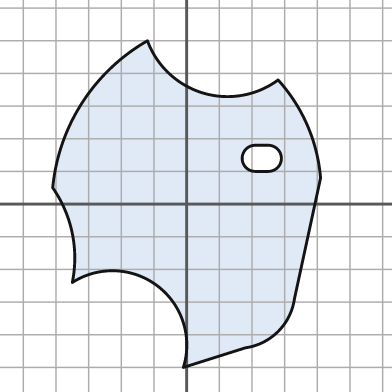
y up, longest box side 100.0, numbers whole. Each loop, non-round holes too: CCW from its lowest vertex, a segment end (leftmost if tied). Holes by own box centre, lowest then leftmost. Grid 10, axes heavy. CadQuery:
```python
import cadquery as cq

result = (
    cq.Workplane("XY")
    .moveTo(-1.0, -50.0)
    .lineTo(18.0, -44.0)
    .threePointArc((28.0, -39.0), (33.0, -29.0))
    .lineTo(41.0, 8.0)
    .threePointArc((37.0, 24.0), (28.0, 38.0))
    .threePointArc((5.0, 34.0), (-12.0, 50.0))
    .threePointArc((-32.0, 31.0), (-41.0, 5.0))
    .threePointArc((-35.0, -9.0), (-35.0, -24.0))
    .threePointArc((-9.0, -25.0), (-1.0, -50.0))
    .close()
    .moveTo(21.0, 10.0)
    .lineTo(25.0, 10.0)
    .threePointArc((29.0, 14.0), (25.0, 18.0))
    .lineTo(21.0, 18.0)
    .threePointArc((17.0, 14.0), (21.0, 10.0))
    .close()
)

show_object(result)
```